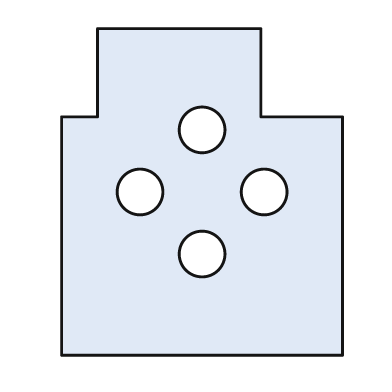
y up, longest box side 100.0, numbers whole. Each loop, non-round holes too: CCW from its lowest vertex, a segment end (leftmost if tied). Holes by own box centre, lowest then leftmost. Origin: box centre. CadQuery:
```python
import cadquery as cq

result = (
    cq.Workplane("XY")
    .moveTo(-43.0, -50.0)
    .lineTo(43.0, -50.0)
    .lineTo(43.0, 23.0)
    .lineTo(18.0, 23.0)
    .lineTo(18.0, 50.0)
    .lineTo(-32.0, 50.0)
    .lineTo(-32.0, 23.0)
    .lineTo(-43.0, 23.0)
    .close()
    .moveTo(0.0, -19.0)
    .circle(7.0)
    .moveTo(-19.0, 0.0)
    .circle(7.0)
    .moveTo(19.0, 0.0)
    .circle(7.0)
    .moveTo(0.0, 19.0)
    .circle(7.0)
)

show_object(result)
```